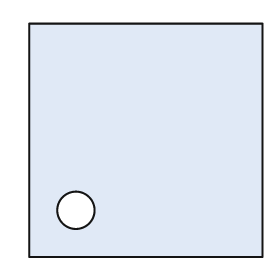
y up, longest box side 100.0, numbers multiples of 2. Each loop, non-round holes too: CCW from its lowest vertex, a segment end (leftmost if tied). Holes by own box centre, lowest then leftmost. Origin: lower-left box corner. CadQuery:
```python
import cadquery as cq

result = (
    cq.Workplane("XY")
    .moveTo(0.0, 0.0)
    .lineTo(100.0, 0.0)
    .lineTo(100.0, 100.0)
    .lineTo(0.0, 100.0)
    .close()
    .moveTo(20.0, 20.0)
    .circle(8.0)
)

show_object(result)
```